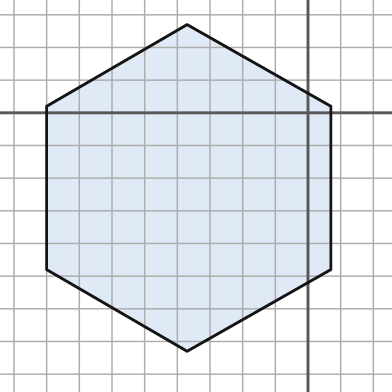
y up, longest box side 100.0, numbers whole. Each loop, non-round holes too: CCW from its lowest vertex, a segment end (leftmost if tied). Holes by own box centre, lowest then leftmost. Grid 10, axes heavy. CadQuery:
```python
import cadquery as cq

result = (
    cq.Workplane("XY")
    .moveTo(-37.0, -73.0)
    .lineTo(7.0, -48.0)
    .lineTo(7.0, 2.0)
    .lineTo(-37.0, 27.0)
    .lineTo(-80.0, 2.0)
    .lineTo(-80.0, -48.0)
    .close()
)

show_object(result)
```